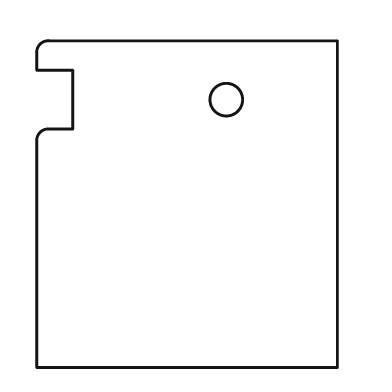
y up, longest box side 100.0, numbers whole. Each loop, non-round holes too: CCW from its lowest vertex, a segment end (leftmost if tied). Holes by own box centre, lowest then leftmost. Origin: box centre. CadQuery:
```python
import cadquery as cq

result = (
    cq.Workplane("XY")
    .moveTo(-46.0, -50.0)
    .lineTo(46.0, -50.0)
    .lineTo(46.0, 50.0)
    .lineTo(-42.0, 50.0)
    .threePointArc((-45.0, 49.0), (-46.0, 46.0))
    .lineTo(-46.0, 41.0)
    .lineTo(-35.0, 41.0)
    .lineTo(-35.0, 23.0)
    .lineTo(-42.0, 23.0)
    .threePointArc((-45.0, 22.0), (-46.0, 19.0))
    .close()
    .moveTo(12.0, 32.0)
    .circle(5.0)
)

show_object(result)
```